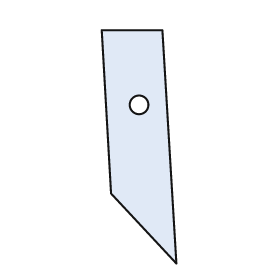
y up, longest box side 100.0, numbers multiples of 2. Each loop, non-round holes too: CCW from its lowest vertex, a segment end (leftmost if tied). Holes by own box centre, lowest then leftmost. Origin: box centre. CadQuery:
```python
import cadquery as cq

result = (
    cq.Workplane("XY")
    .moveTo(16.0, -50.0)
    .lineTo(10.0, 50.0)
    .lineTo(-16.0, 50.0)
    .lineTo(-12.0, -20.0)
    .close()
    .moveTo(0.0, 18.0)
    .circle(4.0)
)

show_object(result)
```